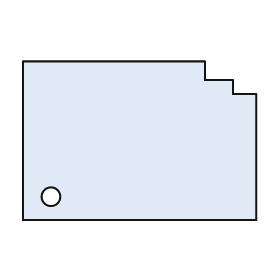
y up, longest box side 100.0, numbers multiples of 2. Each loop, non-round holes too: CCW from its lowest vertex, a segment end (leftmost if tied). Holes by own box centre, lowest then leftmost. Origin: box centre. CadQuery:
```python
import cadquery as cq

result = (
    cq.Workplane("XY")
    .moveTo(-50.0, -34.0)
    .lineTo(50.0, -34.0)
    .lineTo(50.0, 20.0)
    .lineTo(40.0, 20.0)
    .lineTo(40.0, 26.0)
    .lineTo(28.0, 26.0)
    .lineTo(28.0, 34.0)
    .lineTo(-50.0, 34.0)
    .close()
    .moveTo(-38.0, -24.0)
    .circle(4.0)
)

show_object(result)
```